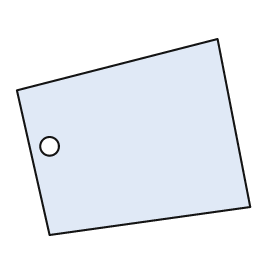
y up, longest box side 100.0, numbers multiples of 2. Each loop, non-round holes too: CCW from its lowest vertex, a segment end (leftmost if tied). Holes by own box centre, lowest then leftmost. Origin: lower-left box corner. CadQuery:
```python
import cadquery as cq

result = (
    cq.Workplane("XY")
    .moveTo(14.0, 0.0)
    .lineTo(100.0, 12.0)
    .lineTo(86.0, 84.0)
    .lineTo(0.0, 62.0)
    .close()
    .moveTo(14.0, 38.0)
    .circle(4.0)
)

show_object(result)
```